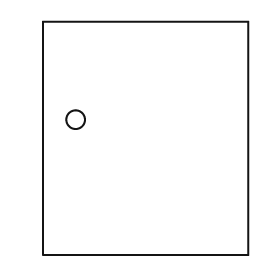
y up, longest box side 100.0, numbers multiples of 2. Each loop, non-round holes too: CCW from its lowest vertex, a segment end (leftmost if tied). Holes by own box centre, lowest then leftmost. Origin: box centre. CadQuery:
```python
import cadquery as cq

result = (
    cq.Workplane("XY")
    .moveTo(-44.0, -50.0)
    .lineTo(44.0, -50.0)
    .lineTo(44.0, 50.0)
    .lineTo(-44.0, 50.0)
    .close()
    .moveTo(-30.0, 8.0)
    .circle(4.0)
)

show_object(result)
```